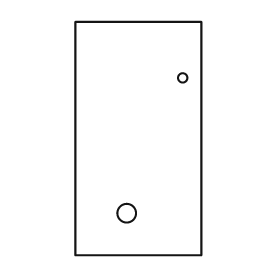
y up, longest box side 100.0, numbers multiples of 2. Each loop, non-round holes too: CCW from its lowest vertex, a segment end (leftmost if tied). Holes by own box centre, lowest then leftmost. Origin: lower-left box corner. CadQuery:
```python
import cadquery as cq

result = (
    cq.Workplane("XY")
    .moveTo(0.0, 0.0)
    .lineTo(54.0, 0.0)
    .lineTo(54.0, 100.0)
    .lineTo(0.0, 100.0)
    .close()
    .moveTo(22.0, 18.0)
    .circle(4.0)
    .moveTo(46.0, 76.0)
    .circle(2.0)
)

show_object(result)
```